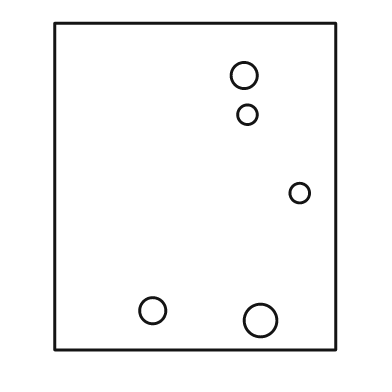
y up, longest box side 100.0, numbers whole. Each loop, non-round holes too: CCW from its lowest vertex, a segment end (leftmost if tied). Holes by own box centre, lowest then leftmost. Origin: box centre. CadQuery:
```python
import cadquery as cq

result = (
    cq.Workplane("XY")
    .moveTo(-43.0, -50.0)
    .lineTo(43.0, -50.0)
    .lineTo(43.0, 50.0)
    .lineTo(-43.0, 50.0)
    .close()
    .moveTo(20.0, -41.0)
    .circle(5.0)
    .moveTo(-13.0, -38.0)
    .circle(4.0)
    .moveTo(32.0, -2.0)
    .circle(3.0)
    .moveTo(16.0, 22.0)
    .circle(3.0)
    .moveTo(15.0, 34.0)
    .circle(4.0)
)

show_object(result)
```